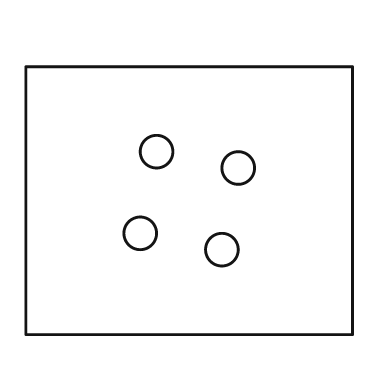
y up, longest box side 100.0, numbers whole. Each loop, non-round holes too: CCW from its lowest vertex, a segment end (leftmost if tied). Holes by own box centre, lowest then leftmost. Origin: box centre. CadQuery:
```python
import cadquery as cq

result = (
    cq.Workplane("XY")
    .moveTo(-50.0, -41.0)
    .lineTo(50.0, -41.0)
    .lineTo(50.0, 41.0)
    .lineTo(-50.0, 41.0)
    .close()
    .moveTo(10.0, -15.0)
    .circle(5.0)
    .moveTo(-15.0, -10.0)
    .circle(5.0)
    .moveTo(15.0, 10.0)
    .circle(5.0)
    .moveTo(-10.0, 15.0)
    .circle(5.0)
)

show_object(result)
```